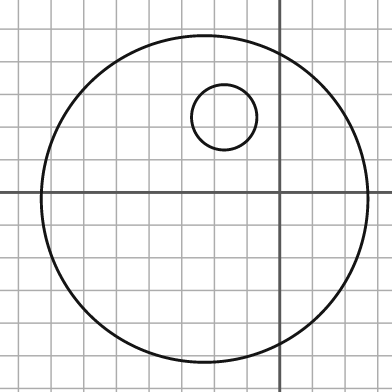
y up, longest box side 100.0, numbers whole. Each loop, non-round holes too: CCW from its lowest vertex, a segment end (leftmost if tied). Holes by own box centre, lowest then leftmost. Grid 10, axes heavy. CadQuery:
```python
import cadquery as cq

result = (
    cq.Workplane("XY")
    .moveTo(-23.0, -2.0)
    .circle(50.0)
    .moveTo(-17.0, 23.0)
    .circle(10.0)
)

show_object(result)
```